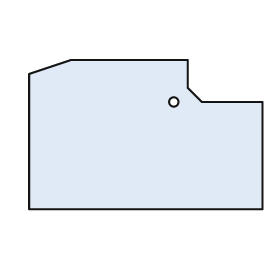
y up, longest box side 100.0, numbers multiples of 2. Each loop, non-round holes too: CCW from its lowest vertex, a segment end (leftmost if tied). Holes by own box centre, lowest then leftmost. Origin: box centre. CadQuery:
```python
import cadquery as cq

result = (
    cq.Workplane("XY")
    .moveTo(-50.0, -32.0)
    .lineTo(50.0, -32.0)
    .lineTo(50.0, 14.0)
    .lineTo(24.0, 14.0)
    .lineTo(18.0, 20.0)
    .lineTo(18.0, 32.0)
    .lineTo(-32.0, 32.0)
    .lineTo(-50.0, 26.0)
    .close()
    .moveTo(12.0, 14.0)
    .circle(2.0)
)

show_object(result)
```